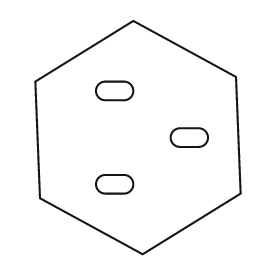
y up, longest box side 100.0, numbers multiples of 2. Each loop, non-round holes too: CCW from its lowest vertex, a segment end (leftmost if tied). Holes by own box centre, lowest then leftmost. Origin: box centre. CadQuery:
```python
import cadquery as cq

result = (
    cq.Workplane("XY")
    .moveTo(2.0, -50.0)
    .lineTo(44.0, -24.0)
    .lineTo(42.0, 26.0)
    .lineTo(-2.0, 50.0)
    .lineTo(-44.0, 24.0)
    .lineTo(-42.0, -26.0)
    .close()
    .moveTo(-14.0, -24.0)
    .lineTo(-6.0, -24.0)
    .threePointArc((-2.0, -20.0), (-6.0, -16.0))
    .lineTo(-14.0, -16.0)
    .threePointArc((-18.0, -20.0), (-14.0, -24.0))
    .close()
    .moveTo(18.0, -4.0)
    .lineTo(26.0, -4.0)
    .threePointArc((30.0, 0.0), (26.0, 4.0))
    .lineTo(18.0, 4.0)
    .threePointArc((14.0, 0.0), (18.0, -4.0))
    .close()
    .moveTo(-14.0, 16.0)
    .lineTo(-6.0, 16.0)
    .threePointArc((-2.0, 20.0), (-6.0, 24.0))
    .lineTo(-14.0, 24.0)
    .threePointArc((-18.0, 20.0), (-14.0, 16.0))
    .close()
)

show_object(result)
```